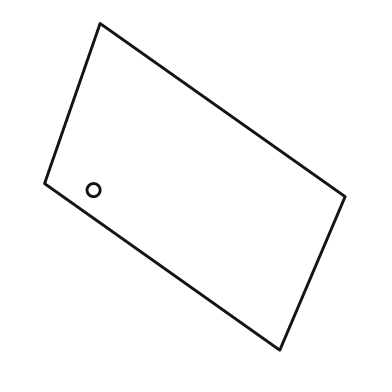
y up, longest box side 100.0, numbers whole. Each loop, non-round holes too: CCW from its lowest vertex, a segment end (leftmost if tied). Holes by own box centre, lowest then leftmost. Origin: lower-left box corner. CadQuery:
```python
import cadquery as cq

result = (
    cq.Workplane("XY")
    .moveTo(72.0, 0.0)
    .lineTo(92.0, 47.0)
    .lineTo(17.0, 100.0)
    .lineTo(0.0, 51.0)
    .close()
    .moveTo(15.0, 49.0)
    .circle(2.0)
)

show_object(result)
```